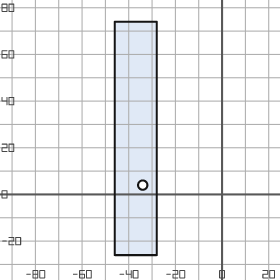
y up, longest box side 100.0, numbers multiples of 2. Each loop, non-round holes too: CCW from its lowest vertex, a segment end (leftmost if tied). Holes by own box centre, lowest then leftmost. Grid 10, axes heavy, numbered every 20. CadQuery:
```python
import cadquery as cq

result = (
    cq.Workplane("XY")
    .moveTo(-46.0, -26.0)
    .lineTo(-28.0, -26.0)
    .lineTo(-28.0, 74.0)
    .lineTo(-46.0, 74.0)
    .close()
    .moveTo(-34.0, 4.0)
    .circle(2.0)
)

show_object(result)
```